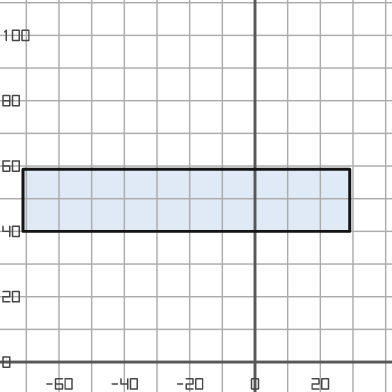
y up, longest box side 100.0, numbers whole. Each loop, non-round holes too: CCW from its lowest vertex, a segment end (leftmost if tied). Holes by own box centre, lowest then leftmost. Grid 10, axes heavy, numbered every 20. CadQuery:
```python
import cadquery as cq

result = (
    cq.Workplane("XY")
    .moveTo(-71.0, 40.0)
    .lineTo(29.0, 40.0)
    .lineTo(29.0, 59.0)
    .lineTo(-71.0, 59.0)
    .close()
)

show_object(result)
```